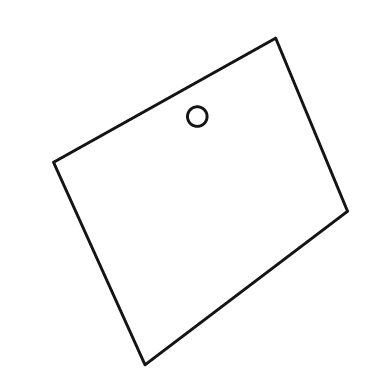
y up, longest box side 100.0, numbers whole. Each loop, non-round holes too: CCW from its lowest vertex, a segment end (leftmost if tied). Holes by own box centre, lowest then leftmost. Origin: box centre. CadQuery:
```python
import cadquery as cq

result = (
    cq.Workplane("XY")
    .moveTo(-17.0, -50.0)
    .lineTo(45.0, -3.0)
    .lineTo(23.0, 50.0)
    .lineTo(-45.0, 12.0)
    .close()
    .moveTo(-1.0, 26.0)
    .circle(3.0)
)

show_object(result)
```